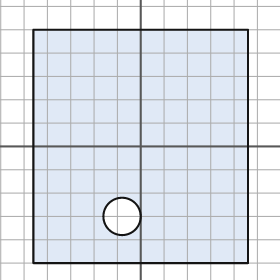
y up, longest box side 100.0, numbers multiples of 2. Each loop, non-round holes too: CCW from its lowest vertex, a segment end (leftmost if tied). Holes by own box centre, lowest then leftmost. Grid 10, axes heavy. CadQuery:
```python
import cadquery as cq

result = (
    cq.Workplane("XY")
    .moveTo(-46.0, -50.0)
    .lineTo(46.0, -50.0)
    .lineTo(46.0, 50.0)
    .lineTo(-46.0, 50.0)
    .close()
    .moveTo(-8.0, -30.0)
    .circle(8.0)
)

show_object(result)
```